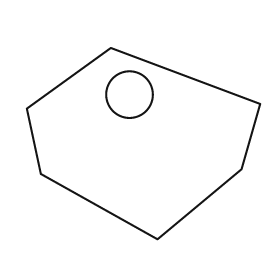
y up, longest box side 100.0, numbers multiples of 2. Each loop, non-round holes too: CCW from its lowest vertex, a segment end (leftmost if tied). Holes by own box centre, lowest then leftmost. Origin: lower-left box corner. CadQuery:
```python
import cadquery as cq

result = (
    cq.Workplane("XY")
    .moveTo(56.0, 0.0)
    .lineTo(92.0, 30.0)
    .lineTo(100.0, 58.0)
    .lineTo(36.0, 82.0)
    .lineTo(0.0, 56.0)
    .lineTo(6.0, 28.0)
    .close()
    .moveTo(44.0, 62.0)
    .circle(10.0)
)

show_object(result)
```